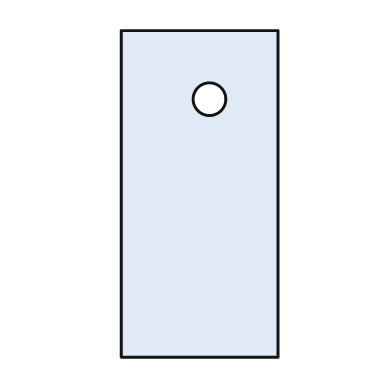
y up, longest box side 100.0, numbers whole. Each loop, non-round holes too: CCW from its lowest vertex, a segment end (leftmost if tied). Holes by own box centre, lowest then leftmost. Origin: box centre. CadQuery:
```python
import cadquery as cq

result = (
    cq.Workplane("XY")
    .moveTo(-24.0, -50.0)
    .lineTo(24.0, -50.0)
    .lineTo(24.0, 50.0)
    .lineTo(-24.0, 50.0)
    .close()
    .moveTo(3.0, 29.0)
    .circle(5.0)
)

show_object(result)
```